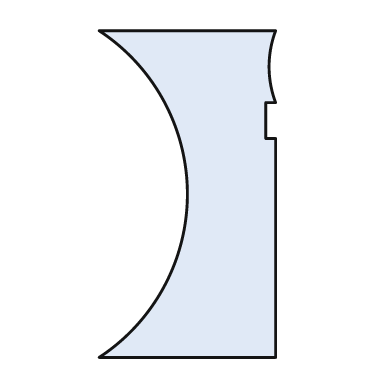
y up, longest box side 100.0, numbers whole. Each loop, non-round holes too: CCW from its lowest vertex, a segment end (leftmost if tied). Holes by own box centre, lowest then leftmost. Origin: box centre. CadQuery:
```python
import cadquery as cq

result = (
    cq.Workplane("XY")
    .moveTo(-27.0, -50.0)
    .lineTo(27.0, -50.0)
    .lineTo(27.0, 17.0)
    .lineTo(24.0, 17.0)
    .lineTo(24.0, 28.0)
    .lineTo(27.0, 28.0)
    .threePointArc((25.0, 39.0), (27.0, 50.0))
    .lineTo(-27.0, 50.0)
    .threePointArc((0.0, 0.0), (-27.0, -50.0))
    .close()
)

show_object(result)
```